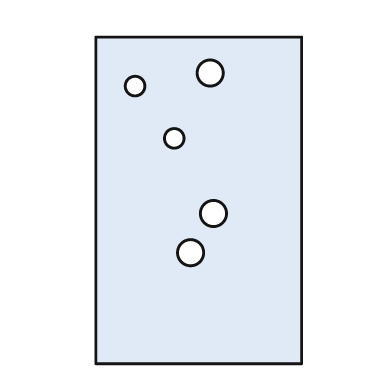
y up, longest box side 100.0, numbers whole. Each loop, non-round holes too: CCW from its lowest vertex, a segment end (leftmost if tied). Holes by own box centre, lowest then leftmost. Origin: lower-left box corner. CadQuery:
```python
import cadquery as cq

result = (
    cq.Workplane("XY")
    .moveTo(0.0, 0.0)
    .lineTo(63.0, 0.0)
    .lineTo(63.0, 100.0)
    .lineTo(0.0, 100.0)
    .close()
    .moveTo(29.0, 34.0)
    .circle(4.0)
    .moveTo(36.0, 46.0)
    .circle(4.0)
    .moveTo(24.0, 69.0)
    .circle(3.0)
    .moveTo(12.0, 85.0)
    .circle(3.0)
    .moveTo(35.0, 89.0)
    .circle(4.0)
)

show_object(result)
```